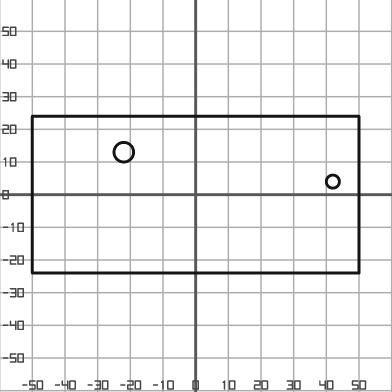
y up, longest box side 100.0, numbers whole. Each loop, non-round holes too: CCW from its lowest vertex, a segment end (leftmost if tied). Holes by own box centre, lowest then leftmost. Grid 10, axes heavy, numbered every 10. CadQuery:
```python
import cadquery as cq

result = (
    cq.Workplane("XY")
    .moveTo(-50.0, -24.0)
    .lineTo(50.0, -24.0)
    .lineTo(50.0, 24.0)
    .lineTo(-50.0, 24.0)
    .close()
    .moveTo(42.0, 4.0)
    .circle(2.0)
    .moveTo(-22.0, 13.0)
    .circle(3.0)
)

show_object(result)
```